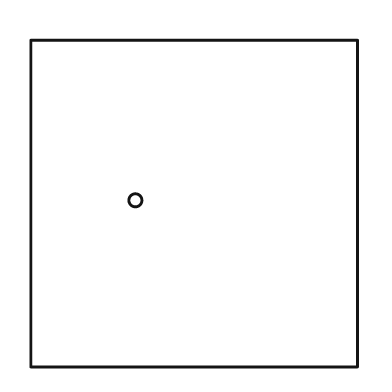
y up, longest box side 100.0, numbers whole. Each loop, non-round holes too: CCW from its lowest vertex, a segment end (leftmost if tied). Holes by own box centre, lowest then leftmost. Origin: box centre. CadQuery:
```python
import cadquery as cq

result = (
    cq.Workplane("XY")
    .moveTo(-50.0, -50.0)
    .lineTo(50.0, -50.0)
    .lineTo(50.0, 50.0)
    .lineTo(-50.0, 50.0)
    .close()
    .moveTo(-18.0, 1.0)
    .circle(2.0)
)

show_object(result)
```